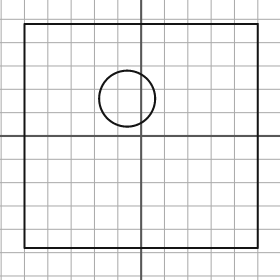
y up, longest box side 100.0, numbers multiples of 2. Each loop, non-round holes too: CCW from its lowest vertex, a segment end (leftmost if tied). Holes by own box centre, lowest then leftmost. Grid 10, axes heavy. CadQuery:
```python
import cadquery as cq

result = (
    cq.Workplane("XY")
    .moveTo(-50.0, -48.0)
    .lineTo(50.0, -48.0)
    .lineTo(50.0, 48.0)
    .lineTo(-50.0, 48.0)
    .close()
    .moveTo(-6.0, 16.0)
    .circle(12.0)
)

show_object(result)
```